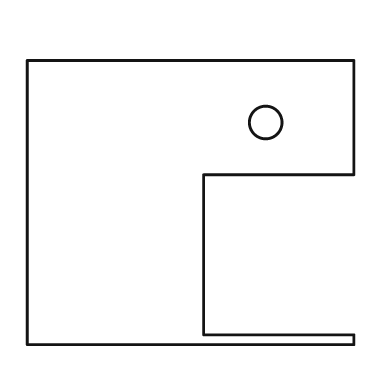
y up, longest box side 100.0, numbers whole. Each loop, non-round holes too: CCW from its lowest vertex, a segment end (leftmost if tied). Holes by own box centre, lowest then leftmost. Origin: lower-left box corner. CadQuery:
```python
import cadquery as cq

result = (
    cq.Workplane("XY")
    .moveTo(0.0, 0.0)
    .lineTo(100.0, 0.0)
    .lineTo(100.0, 3.0)
    .lineTo(54.0, 3.0)
    .lineTo(54.0, 52.0)
    .lineTo(100.0, 52.0)
    .lineTo(100.0, 87.0)
    .lineTo(0.0, 87.0)
    .close()
    .moveTo(73.0, 68.0)
    .circle(5.0)
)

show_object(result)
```